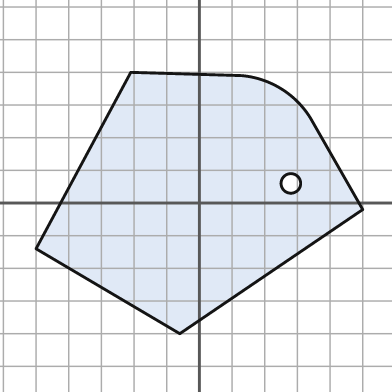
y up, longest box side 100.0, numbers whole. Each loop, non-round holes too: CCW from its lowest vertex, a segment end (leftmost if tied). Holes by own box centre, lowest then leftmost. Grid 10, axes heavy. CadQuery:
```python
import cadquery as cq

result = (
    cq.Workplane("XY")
    .moveTo(-6.0, -40.0)
    .lineTo(50.0, -2.0)
    .lineTo(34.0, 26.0)
    .threePointArc((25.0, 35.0), (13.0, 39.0))
    .lineTo(-21.0, 40.0)
    .lineTo(-50.0, -14.0)
    .close()
    .moveTo(28.0, 6.0)
    .circle(3.0)
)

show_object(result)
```